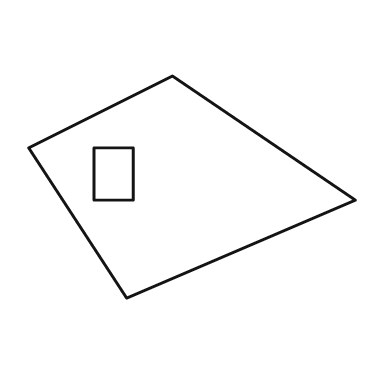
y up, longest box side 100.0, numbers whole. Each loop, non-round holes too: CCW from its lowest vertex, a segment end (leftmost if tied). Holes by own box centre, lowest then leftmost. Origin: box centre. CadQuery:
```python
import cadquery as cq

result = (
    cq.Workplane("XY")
    .moveTo(-20.0, -34.0)
    .lineTo(50.0, -4.0)
    .lineTo(-6.0, 34.0)
    .lineTo(-50.0, 12.0)
    .close()
    .moveTo(-30.0, -4.0)
    .lineTo(-18.0, -4.0)
    .lineTo(-18.0, 12.0)
    .lineTo(-30.0, 12.0)
    .close()
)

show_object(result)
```